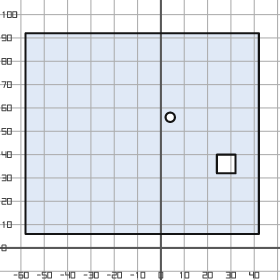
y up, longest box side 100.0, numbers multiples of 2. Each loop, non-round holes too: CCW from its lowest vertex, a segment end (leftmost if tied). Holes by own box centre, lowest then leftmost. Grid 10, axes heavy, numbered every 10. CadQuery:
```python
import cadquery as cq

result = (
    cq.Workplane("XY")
    .moveTo(-58.0, 6.0)
    .lineTo(42.0, 6.0)
    .lineTo(42.0, 92.0)
    .lineTo(-58.0, 92.0)
    .close()
    .moveTo(24.0, 32.0)
    .lineTo(32.0, 32.0)
    .lineTo(32.0, 40.0)
    .lineTo(24.0, 40.0)
    .close()
    .moveTo(4.0, 56.0)
    .circle(2.0)
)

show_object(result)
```